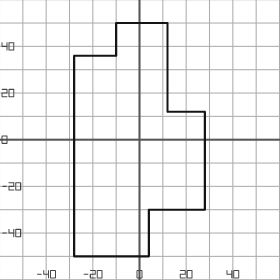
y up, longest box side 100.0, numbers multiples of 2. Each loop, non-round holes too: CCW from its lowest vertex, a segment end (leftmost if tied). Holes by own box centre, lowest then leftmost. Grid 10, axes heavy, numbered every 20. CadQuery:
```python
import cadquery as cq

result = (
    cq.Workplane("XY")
    .moveTo(-28.0, -50.0)
    .lineTo(4.0, -50.0)
    .lineTo(4.0, -30.0)
    .lineTo(28.0, -30.0)
    .lineTo(28.0, 12.0)
    .lineTo(12.0, 12.0)
    .lineTo(12.0, 50.0)
    .lineTo(-10.0, 50.0)
    .lineTo(-10.0, 36.0)
    .lineTo(-28.0, 36.0)
    .close()
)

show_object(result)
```